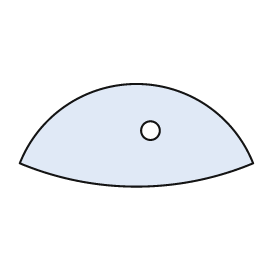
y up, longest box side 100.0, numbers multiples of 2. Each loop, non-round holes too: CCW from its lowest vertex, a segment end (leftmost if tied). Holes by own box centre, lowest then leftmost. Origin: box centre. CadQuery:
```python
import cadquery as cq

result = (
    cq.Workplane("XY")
    .moveTo(-50.0, -12.0)
    .threePointArc((0.0, -22.0), (50.0, -12.0))
    .threePointArc((0.0, 22.0), (-50.0, -12.0))
    .close()
    .moveTo(6.0, 2.0)
    .circle(4.0)
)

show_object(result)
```